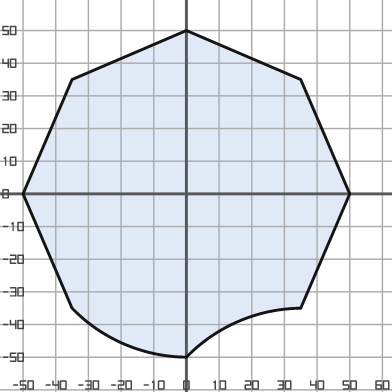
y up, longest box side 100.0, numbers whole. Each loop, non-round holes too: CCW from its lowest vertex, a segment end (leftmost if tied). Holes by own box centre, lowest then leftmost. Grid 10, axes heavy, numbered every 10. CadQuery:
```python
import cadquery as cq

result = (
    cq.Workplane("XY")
    .moveTo(0.0, -50.0)
    .threePointArc((16.0, -39.0), (35.0, -35.0))
    .lineTo(50.0, 0.0)
    .lineTo(35.0, 35.0)
    .lineTo(0.0, 50.0)
    .lineTo(-35.0, 35.0)
    .lineTo(-50.0, 0.0)
    .lineTo(-35.0, -35.0)
    .threePointArc((-19.0, -46.0), (0.0, -50.0))
    .close()
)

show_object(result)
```